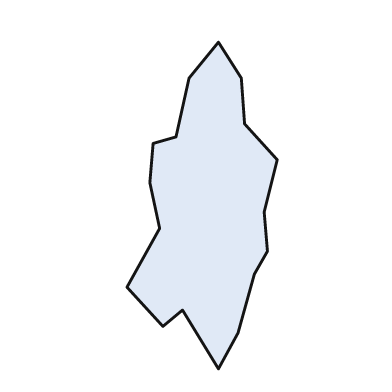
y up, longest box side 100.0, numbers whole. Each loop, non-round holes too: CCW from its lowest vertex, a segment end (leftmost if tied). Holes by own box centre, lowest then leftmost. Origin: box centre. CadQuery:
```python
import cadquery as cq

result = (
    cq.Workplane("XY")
    .moveTo(5.0, -50.0)
    .lineTo(11.0, -39.0)
    .lineTo(16.0, -21.0)
    .lineTo(20.0, -14.0)
    .lineTo(19.0, -2.0)
    .lineTo(23.0, 14.0)
    .lineTo(13.0, 25.0)
    .lineTo(12.0, 39.0)
    .lineTo(5.0, 50.0)
    .lineTo(-4.0, 39.0)
    .lineTo(-8.0, 21.0)
    .lineTo(-15.0, 19.0)
    .lineTo(-16.0, 7.0)
    .lineTo(-13.0, -7.0)
    .lineTo(-23.0, -25.0)
    .lineTo(-12.0, -37.0)
    .lineTo(-6.0, -32.0)
    .close()
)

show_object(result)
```